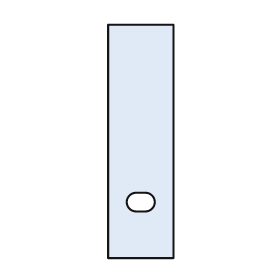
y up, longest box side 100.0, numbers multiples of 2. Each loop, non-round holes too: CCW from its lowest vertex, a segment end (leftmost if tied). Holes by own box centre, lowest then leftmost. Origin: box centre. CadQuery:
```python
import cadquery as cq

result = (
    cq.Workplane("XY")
    .moveTo(-14.0, -50.0)
    .lineTo(14.0, -50.0)
    .lineTo(14.0, 50.0)
    .lineTo(-14.0, 50.0)
    .close()
    .moveTo(-2.0, -30.0)
    .lineTo(2.0, -30.0)
    .threePointArc((6.0, -26.0), (2.0, -22.0))
    .lineTo(-2.0, -22.0)
    .threePointArc((-6.0, -26.0), (-2.0, -30.0))
    .close()
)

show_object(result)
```